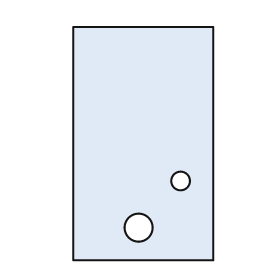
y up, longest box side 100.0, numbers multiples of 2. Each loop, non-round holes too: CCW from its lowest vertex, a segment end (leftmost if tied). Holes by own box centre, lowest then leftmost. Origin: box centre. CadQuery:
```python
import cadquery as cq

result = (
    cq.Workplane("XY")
    .moveTo(-30.0, -50.0)
    .lineTo(30.0, -50.0)
    .lineTo(30.0, 50.0)
    .lineTo(-30.0, 50.0)
    .close()
    .moveTo(-2.0, -36.0)
    .circle(6.0)
    .moveTo(16.0, -16.0)
    .circle(4.0)
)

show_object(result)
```